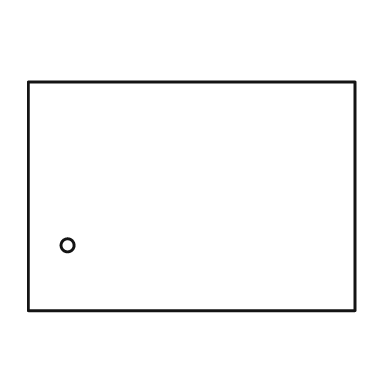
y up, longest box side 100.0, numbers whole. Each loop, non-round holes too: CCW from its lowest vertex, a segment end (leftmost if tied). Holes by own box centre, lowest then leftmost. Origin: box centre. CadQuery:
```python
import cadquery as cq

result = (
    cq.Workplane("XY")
    .moveTo(-50.0, -35.0)
    .lineTo(50.0, -35.0)
    .lineTo(50.0, 35.0)
    .lineTo(-50.0, 35.0)
    .close()
    .moveTo(-38.0, -15.0)
    .circle(2.0)
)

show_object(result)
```